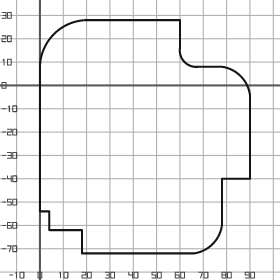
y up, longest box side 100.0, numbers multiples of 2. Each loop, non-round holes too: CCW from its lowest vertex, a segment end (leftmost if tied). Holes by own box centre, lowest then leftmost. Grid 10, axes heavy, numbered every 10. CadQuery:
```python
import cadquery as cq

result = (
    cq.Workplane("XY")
    .moveTo(18.0, -72.0)
    .lineTo(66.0, -72.0)
    .threePointArc((74.0, -68.0), (78.0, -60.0))
    .lineTo(78.0, -40.0)
    .lineTo(90.0, -40.0)
    .lineTo(90.0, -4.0)
    .threePointArc((86.0, 4.0), (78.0, 8.0))
    .lineTo(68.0, 8.0)
    .threePointArc((62.0, 10.0), (60.0, 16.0))
    .lineTo(60.0, 28.0)
    .lineTo(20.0, 28.0)
    .threePointArc((6.0, 22.0), (0.0, 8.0))
    .lineTo(0.0, -54.0)
    .lineTo(4.0, -54.0)
    .lineTo(4.0, -62.0)
    .lineTo(18.0, -62.0)
    .close()
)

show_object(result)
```